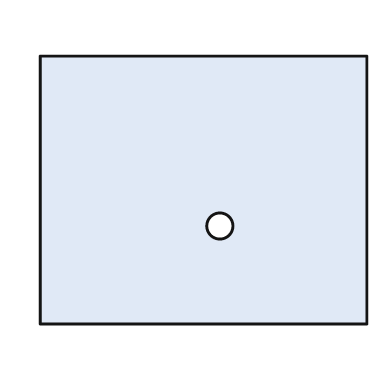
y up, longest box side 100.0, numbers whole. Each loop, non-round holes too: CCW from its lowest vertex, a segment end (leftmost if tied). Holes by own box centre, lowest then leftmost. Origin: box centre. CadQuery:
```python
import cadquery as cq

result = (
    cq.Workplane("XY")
    .moveTo(-50.0, -41.0)
    .lineTo(50.0, -41.0)
    .lineTo(50.0, 41.0)
    .lineTo(-50.0, 41.0)
    .close()
    .moveTo(5.0, -11.0)
    .circle(4.0)
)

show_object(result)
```